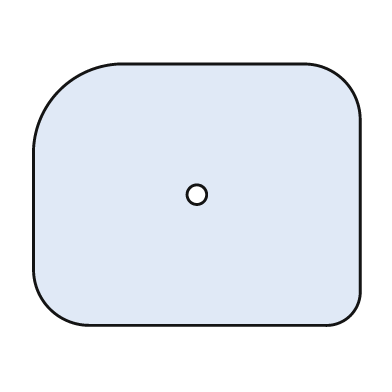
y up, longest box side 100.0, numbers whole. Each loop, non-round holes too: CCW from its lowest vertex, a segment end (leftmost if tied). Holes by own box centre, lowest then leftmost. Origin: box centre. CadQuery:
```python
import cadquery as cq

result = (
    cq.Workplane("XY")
    .moveTo(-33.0, -40.0)
    .lineTo(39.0, -40.0)
    .threePointArc((47.0, -37.0), (50.0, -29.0))
    .lineTo(50.0, 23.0)
    .threePointArc((45.0, 35.0), (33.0, 40.0))
    .lineTo(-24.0, 40.0)
    .threePointArc((-42.0, 32.0), (-50.0, 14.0))
    .lineTo(-50.0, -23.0)
    .threePointArc((-45.0, -35.0), (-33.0, -40.0))
    .close()
    .moveTo(0.0, 0.0)
    .circle(3.0)
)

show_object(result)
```